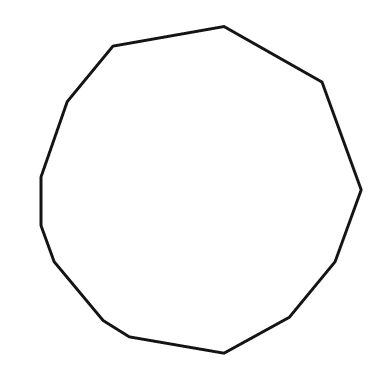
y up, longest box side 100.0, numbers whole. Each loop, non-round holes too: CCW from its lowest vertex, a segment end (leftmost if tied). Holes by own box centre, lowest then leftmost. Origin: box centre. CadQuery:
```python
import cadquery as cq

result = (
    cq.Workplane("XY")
    .moveTo(7.0, -50.0)
    .lineTo(27.0, -39.0)
    .lineTo(41.0, -22.0)
    .lineTo(49.0, 0.0)
    .lineTo(37.0, 33.0)
    .lineTo(7.0, 50.0)
    .lineTo(-27.0, 44.0)
    .lineTo(-41.0, 27.0)
    .lineTo(-49.0, 4.0)
    .lineTo(-49.0, -11.0)
    .lineTo(-45.0, -22.0)
    .lineTo(-30.0, -40.0)
    .lineTo(-22.0, -45.0)
    .close()
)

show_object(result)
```